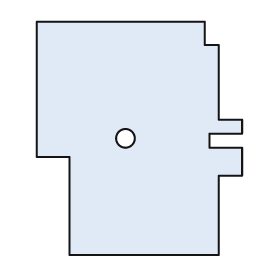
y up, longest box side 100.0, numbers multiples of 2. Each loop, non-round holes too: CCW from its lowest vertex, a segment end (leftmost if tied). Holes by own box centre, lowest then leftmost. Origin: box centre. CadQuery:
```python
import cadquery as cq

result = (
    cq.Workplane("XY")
    .moveTo(-30.0, -50.0)
    .lineTo(34.0, -50.0)
    .lineTo(34.0, -16.0)
    .lineTo(44.0, -16.0)
    .lineTo(44.0, -4.0)
    .lineTo(30.0, -4.0)
    .lineTo(30.0, 2.0)
    .lineTo(44.0, 2.0)
    .lineTo(44.0, 8.0)
    .lineTo(34.0, 8.0)
    .lineTo(34.0, 40.0)
    .lineTo(28.0, 40.0)
    .lineTo(28.0, 50.0)
    .lineTo(-44.0, 50.0)
    .lineTo(-44.0, -8.0)
    .lineTo(-30.0, -8.0)
    .close()
    .moveTo(-6.0, 0.0)
    .circle(4.0)
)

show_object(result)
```